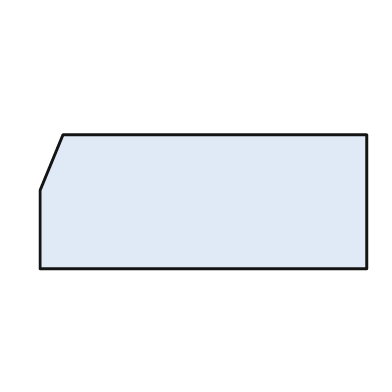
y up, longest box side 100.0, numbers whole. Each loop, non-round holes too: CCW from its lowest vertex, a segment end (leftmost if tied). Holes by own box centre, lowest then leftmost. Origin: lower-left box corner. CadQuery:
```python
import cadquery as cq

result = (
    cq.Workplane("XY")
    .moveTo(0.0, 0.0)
    .lineTo(100.0, 0.0)
    .lineTo(100.0, 41.0)
    .lineTo(7.0, 41.0)
    .lineTo(0.0, 24.0)
    .close()
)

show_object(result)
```